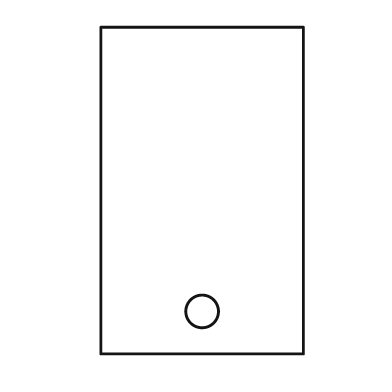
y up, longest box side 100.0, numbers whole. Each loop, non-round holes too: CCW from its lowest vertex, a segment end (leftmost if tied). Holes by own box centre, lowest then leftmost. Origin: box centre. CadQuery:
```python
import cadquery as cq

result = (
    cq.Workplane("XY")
    .moveTo(-31.0, -50.0)
    .lineTo(31.0, -50.0)
    .lineTo(31.0, 50.0)
    .lineTo(-31.0, 50.0)
    .close()
    .moveTo(0.0, -37.0)
    .circle(5.0)
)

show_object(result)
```